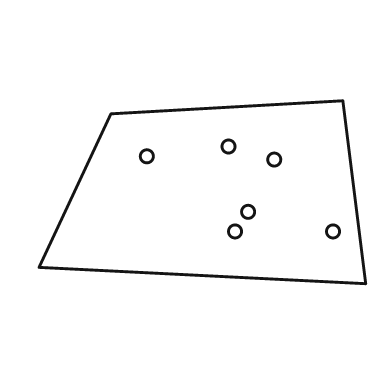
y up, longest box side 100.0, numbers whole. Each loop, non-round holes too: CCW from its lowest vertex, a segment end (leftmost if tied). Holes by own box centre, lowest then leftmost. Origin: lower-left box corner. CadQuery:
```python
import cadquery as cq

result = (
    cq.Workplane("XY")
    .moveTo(100.0, 0.0)
    .lineTo(93.0, 56.0)
    .lineTo(22.0, 52.0)
    .lineTo(0.0, 5.0)
    .close()
    .moveTo(60.0, 16.0)
    .circle(2.0)
    .moveTo(90.0, 16.0)
    .circle(2.0)
    .moveTo(64.0, 22.0)
    .circle(2.0)
    .moveTo(72.0, 38.0)
    .circle(2.0)
    .moveTo(33.0, 39.0)
    .circle(2.0)
    .moveTo(58.0, 42.0)
    .circle(2.0)
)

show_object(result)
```